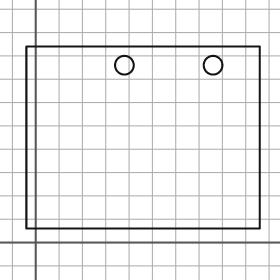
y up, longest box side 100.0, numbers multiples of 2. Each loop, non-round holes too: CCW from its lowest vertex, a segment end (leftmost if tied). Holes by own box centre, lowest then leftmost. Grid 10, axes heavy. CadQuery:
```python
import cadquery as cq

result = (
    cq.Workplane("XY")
    .moveTo(-4.0, 6.0)
    .lineTo(96.0, 6.0)
    .lineTo(96.0, 84.0)
    .lineTo(-4.0, 84.0)
    .close()
    .moveTo(38.0, 76.0)
    .circle(4.0)
    .moveTo(76.0, 76.0)
    .circle(4.0)
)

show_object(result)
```